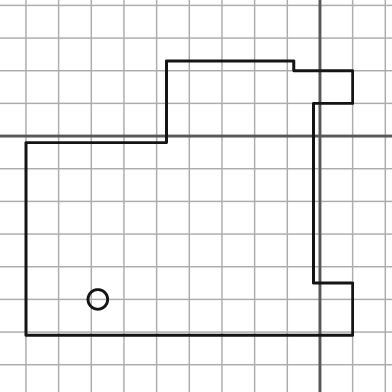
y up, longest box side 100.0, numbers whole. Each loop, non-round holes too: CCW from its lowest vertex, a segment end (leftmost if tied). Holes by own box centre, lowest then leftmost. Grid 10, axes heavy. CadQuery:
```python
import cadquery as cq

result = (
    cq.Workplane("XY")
    .moveTo(-90.0, -61.0)
    .lineTo(10.0, -61.0)
    .lineTo(10.0, -45.0)
    .lineTo(-2.0, -45.0)
    .lineTo(-2.0, 10.0)
    .lineTo(10.0, 10.0)
    .lineTo(10.0, 20.0)
    .lineTo(-8.0, 20.0)
    .lineTo(-8.0, 23.0)
    .lineTo(-47.0, 23.0)
    .lineTo(-47.0, -2.0)
    .lineTo(-90.0, -2.0)
    .close()
    .moveTo(-68.0, -50.0)
    .circle(3.0)
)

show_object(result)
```